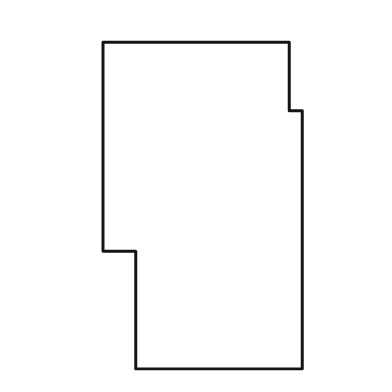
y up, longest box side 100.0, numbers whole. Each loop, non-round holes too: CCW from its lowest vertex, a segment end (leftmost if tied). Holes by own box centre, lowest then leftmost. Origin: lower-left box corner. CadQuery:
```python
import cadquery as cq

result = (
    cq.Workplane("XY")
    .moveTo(10.0, 0.0)
    .lineTo(61.0, 0.0)
    .lineTo(61.0, 79.0)
    .lineTo(57.0, 79.0)
    .lineTo(57.0, 100.0)
    .lineTo(0.0, 100.0)
    .lineTo(0.0, 36.0)
    .lineTo(10.0, 36.0)
    .close()
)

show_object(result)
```